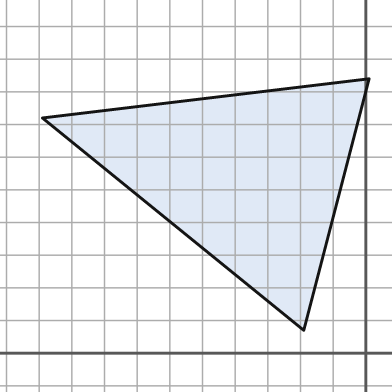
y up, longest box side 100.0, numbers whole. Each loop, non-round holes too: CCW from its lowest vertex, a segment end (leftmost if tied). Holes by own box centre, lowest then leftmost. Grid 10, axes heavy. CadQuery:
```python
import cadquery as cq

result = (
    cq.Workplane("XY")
    .moveTo(-19.0, 7.0)
    .lineTo(1.0, 84.0)
    .lineTo(-99.0, 72.0)
    .close()
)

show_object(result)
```